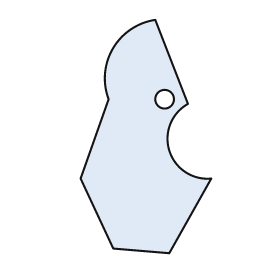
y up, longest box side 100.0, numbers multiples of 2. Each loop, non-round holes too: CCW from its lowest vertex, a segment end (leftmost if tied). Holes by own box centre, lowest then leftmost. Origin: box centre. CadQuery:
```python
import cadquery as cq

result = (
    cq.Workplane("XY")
    .moveTo(10.0, -50.0)
    .lineTo(28.0, -18.0)
    .threePointArc((10.0, -6.0), (18.0, 14.0))
    .lineTo(4.0, 50.0)
    .threePointArc((-14.0, 38.0), (-16.0, 16.0))
    .lineTo(-28.0, -18.0)
    .lineTo(-14.0, -48.0)
    .close()
    .moveTo(8.0, 16.0)
    .circle(4.0)
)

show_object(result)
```